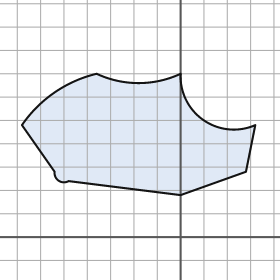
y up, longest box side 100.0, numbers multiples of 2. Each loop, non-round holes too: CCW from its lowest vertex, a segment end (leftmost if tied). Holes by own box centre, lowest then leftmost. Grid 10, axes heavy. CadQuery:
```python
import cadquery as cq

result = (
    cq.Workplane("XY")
    .moveTo(0.0, 18.0)
    .lineTo(28.0, 28.0)
    .lineTo(32.0, 48.0)
    .threePointArc((10.0, 50.0), (0.0, 70.0))
    .threePointArc((-18.0, 66.0), (-36.0, 70.0))
    .threePointArc((-54.0, 62.0), (-68.0, 48.0))
    .lineTo(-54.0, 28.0)
    .threePointArc((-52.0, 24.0), (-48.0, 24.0))
    .close()
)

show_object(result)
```